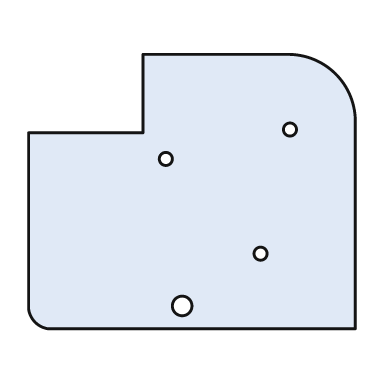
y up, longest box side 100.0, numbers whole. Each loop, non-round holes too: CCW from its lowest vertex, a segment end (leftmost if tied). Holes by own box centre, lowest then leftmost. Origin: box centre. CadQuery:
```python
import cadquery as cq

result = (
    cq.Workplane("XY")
    .moveTo(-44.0, -42.0)
    .lineTo(50.0, -42.0)
    .lineTo(50.0, 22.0)
    .threePointArc((44.0, 36.0), (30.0, 42.0))
    .lineTo(-15.0, 42.0)
    .lineTo(-15.0, 18.0)
    .lineTo(-50.0, 18.0)
    .lineTo(-50.0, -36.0)
    .threePointArc((-48.0, -40.0), (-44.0, -42.0))
    .close()
    .moveTo(-3.0, -35.0)
    .circle(3.0)
    .moveTo(21.0, -19.0)
    .circle(2.0)
    .moveTo(-8.0, 10.0)
    .circle(2.0)
    .moveTo(30.0, 19.0)
    .circle(2.0)
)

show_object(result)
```